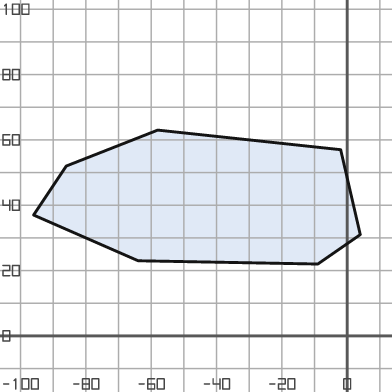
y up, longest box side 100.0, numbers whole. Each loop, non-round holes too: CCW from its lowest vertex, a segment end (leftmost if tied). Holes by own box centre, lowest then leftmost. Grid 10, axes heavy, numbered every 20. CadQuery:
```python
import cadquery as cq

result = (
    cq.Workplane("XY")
    .moveTo(-9.0, 22.0)
    .lineTo(4.0, 31.0)
    .lineTo(-2.0, 57.0)
    .lineTo(-58.0, 63.0)
    .lineTo(-86.0, 52.0)
    .lineTo(-96.0, 37.0)
    .lineTo(-64.0, 23.0)
    .close()
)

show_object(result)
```